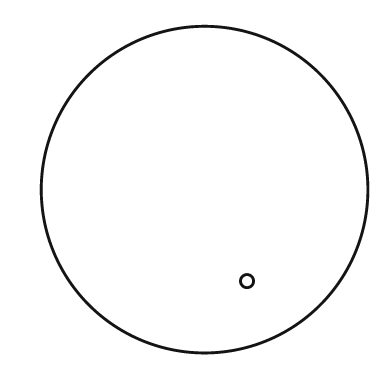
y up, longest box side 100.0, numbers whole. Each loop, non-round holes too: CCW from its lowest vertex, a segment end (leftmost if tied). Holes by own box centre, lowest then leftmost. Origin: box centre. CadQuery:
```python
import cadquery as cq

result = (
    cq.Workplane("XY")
    .moveTo(0.0, 0.0)
    .circle(50.0)
    .moveTo(13.0, -28.0)
    .circle(2.0)
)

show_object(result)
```